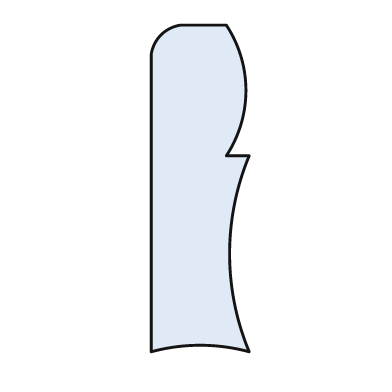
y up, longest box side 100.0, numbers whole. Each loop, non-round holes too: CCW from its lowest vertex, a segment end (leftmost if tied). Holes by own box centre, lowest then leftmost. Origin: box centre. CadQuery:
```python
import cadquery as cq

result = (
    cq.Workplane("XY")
    .moveTo(-15.0, -50.0)
    .threePointArc((0.0, -48.0), (15.0, -50.0))
    .threePointArc((9.0, -20.0), (15.0, 10.0))
    .lineTo(8.0, 10.0)
    .threePointArc((14.0, 30.0), (8.0, 50.0))
    .lineTo(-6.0, 50.0)
    .threePointArc((-12.0, 47.0), (-15.0, 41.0))
    .close()
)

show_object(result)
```